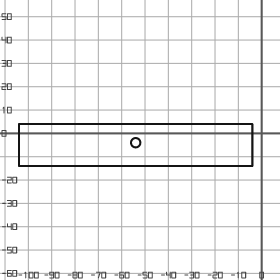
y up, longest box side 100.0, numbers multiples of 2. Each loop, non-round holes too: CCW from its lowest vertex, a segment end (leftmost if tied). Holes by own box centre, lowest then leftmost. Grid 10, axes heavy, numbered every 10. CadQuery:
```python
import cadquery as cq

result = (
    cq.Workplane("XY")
    .moveTo(-104.0, -14.0)
    .lineTo(-4.0, -14.0)
    .lineTo(-4.0, 4.0)
    .lineTo(-104.0, 4.0)
    .close()
    .moveTo(-54.0, -4.0)
    .circle(2.0)
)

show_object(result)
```